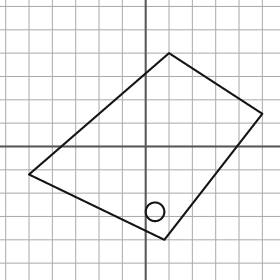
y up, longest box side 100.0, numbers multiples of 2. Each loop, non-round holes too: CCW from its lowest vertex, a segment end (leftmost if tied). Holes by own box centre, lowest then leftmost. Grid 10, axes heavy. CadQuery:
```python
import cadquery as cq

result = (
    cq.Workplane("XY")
    .moveTo(8.0, -40.0)
    .lineTo(50.0, 14.0)
    .lineTo(10.0, 40.0)
    .lineTo(-50.0, -12.0)
    .close()
    .moveTo(4.0, -28.0)
    .circle(4.0)
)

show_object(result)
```